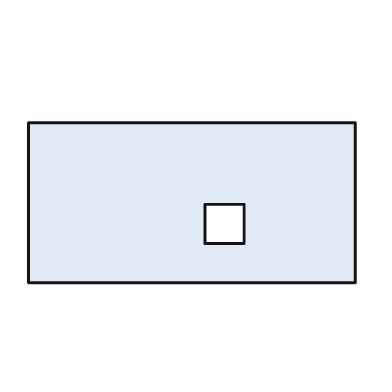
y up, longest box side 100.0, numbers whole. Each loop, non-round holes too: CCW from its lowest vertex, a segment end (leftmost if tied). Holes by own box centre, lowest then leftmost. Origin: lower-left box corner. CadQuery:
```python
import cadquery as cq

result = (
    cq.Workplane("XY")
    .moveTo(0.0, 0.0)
    .lineTo(100.0, 0.0)
    .lineTo(100.0, 49.0)
    .lineTo(0.0, 49.0)
    .close()
    .moveTo(54.0, 12.0)
    .lineTo(66.0, 12.0)
    .lineTo(66.0, 24.0)
    .lineTo(54.0, 24.0)
    .close()
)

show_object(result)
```